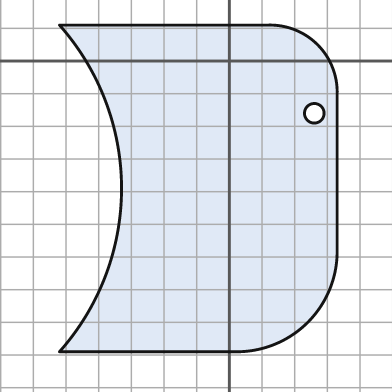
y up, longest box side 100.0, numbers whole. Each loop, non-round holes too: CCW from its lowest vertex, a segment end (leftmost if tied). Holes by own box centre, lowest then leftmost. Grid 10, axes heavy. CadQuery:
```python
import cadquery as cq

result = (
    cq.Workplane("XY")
    .moveTo(-52.0, -89.0)
    .lineTo(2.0, -89.0)
    .threePointArc((24.0, -80.0), (33.0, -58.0))
    .lineTo(33.0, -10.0)
    .threePointArc((27.0, 5.0), (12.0, 11.0))
    .lineTo(-52.0, 11.0)
    .threePointArc((-33.0, -39.0), (-52.0, -89.0))
    .close()
    .moveTo(26.0, -16.0)
    .circle(3.0)
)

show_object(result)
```